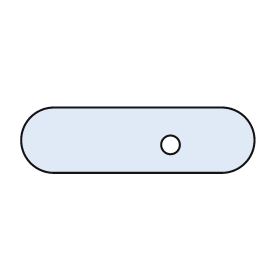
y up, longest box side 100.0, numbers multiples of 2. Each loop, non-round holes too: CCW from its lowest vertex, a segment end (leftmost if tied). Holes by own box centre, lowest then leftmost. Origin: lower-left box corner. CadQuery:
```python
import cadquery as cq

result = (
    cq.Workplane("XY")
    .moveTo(14.0, 0.0)
    .lineTo(86.0, 0.0)
    .threePointArc((100.0, 14.0), (86.0, 28.0))
    .lineTo(14.0, 28.0)
    .threePointArc((0.0, 14.0), (14.0, 0.0))
    .close()
    .moveTo(64.0, 12.0)
    .circle(4.0)
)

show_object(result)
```